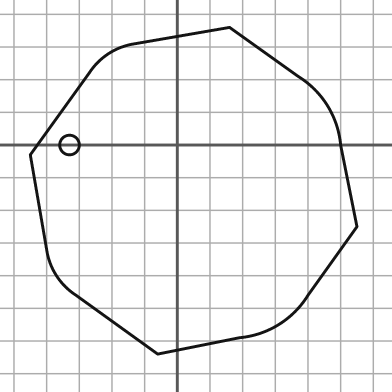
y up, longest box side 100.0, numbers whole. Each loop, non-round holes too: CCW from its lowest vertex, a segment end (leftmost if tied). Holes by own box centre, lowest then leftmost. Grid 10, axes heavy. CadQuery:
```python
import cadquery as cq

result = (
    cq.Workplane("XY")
    .moveTo(-6.0, -64.0)
    .lineTo(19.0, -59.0)
    .threePointArc((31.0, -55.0), (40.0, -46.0))
    .lineTo(55.0, -25.0)
    .lineTo(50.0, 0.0)
    .threePointArc((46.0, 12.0), (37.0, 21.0))
    .lineTo(16.0, 36.0)
    .lineTo(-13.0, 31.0)
    .threePointArc((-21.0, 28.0), (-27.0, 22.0))
    .lineTo(-45.0, -3.0)
    .lineTo(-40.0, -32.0)
    .threePointArc((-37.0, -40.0), (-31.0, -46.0))
    .close()
    .moveTo(-33.0, 0.0)
    .circle(3.0)
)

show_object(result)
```